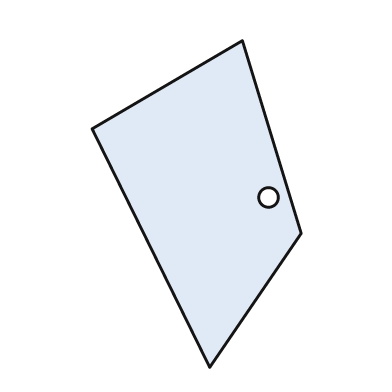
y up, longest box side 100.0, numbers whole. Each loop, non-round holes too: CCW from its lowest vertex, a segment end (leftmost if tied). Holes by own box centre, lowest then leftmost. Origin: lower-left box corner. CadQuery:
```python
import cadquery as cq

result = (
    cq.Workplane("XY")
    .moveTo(36.0, 0.0)
    .lineTo(64.0, 41.0)
    .lineTo(46.0, 100.0)
    .lineTo(0.0, 73.0)
    .close()
    .moveTo(54.0, 52.0)
    .circle(3.0)
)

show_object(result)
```